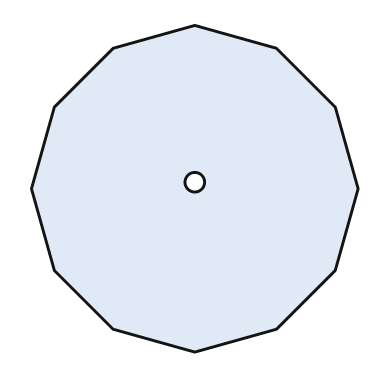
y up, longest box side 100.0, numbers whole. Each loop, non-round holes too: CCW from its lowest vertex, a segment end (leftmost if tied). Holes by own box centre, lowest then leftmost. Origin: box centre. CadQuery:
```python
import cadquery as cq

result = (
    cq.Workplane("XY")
    .moveTo(0.0, -50.0)
    .lineTo(25.0, -43.0)
    .lineTo(43.0, -25.0)
    .lineTo(50.0, 0.0)
    .lineTo(43.0, 25.0)
    .lineTo(25.0, 43.0)
    .lineTo(0.0, 50.0)
    .lineTo(-25.0, 43.0)
    .lineTo(-43.0, 25.0)
    .lineTo(-50.0, 0.0)
    .lineTo(-43.0, -25.0)
    .lineTo(-25.0, -43.0)
    .close()
    .moveTo(0.0, 2.0)
    .circle(3.0)
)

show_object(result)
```